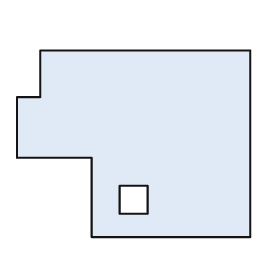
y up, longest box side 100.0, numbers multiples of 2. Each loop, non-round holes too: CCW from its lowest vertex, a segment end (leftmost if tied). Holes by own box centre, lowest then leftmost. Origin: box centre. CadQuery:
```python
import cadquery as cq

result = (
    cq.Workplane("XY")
    .moveTo(-18.0, -40.0)
    .lineTo(50.0, -40.0)
    .lineTo(50.0, 40.0)
    .lineTo(-40.0, 40.0)
    .lineTo(-40.0, 20.0)
    .lineTo(-50.0, 20.0)
    .lineTo(-50.0, -6.0)
    .lineTo(-18.0, -6.0)
    .close()
    .moveTo(-6.0, -30.0)
    .lineTo(6.0, -30.0)
    .lineTo(6.0, -18.0)
    .lineTo(-6.0, -18.0)
    .close()
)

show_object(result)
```